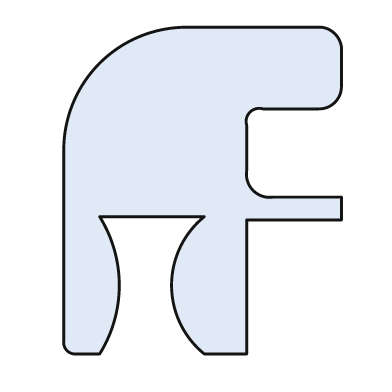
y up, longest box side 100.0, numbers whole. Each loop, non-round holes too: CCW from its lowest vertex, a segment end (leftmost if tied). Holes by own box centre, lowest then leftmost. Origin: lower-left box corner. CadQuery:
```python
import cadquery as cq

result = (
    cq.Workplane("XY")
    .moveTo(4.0, 0.0)
    .lineTo(11.0, 0.0)
    .threePointArc((17.0, 21.0), (11.0, 42.0))
    .lineTo(43.0, 42.0)
    .threePointArc((33.0, 21.0), (43.0, 0.0))
    .lineTo(56.0, 0.0)
    .lineTo(56.0, 41.0)
    .lineTo(85.0, 41.0)
    .lineTo(85.0, 48.0)
    .lineTo(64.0, 48.0)
    .threePointArc((58.0, 50.0), (56.0, 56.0))
    .lineTo(56.0, 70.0)
    .threePointArc((57.0, 74.0), (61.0, 75.0))
    .lineTo(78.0, 75.0)
    .threePointArc((83.0, 77.0), (85.0, 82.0))
    .lineTo(85.0, 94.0)
    .threePointArc((83.0, 98.0), (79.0, 100.0))
    .lineTo(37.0, 100.0)
    .threePointArc((11.0, 89.0), (0.0, 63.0))
    .lineTo(0.0, 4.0)
    .threePointArc((1.0, 1.0), (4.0, 0.0))
    .close()
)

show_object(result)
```